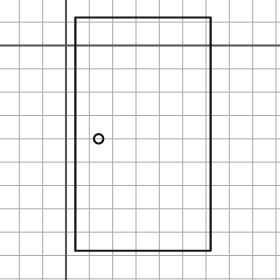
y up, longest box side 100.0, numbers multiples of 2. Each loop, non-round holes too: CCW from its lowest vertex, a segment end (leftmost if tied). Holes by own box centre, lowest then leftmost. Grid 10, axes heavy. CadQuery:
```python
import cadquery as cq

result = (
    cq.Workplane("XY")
    .moveTo(4.0, -88.0)
    .lineTo(62.0, -88.0)
    .lineTo(62.0, 12.0)
    .lineTo(4.0, 12.0)
    .close()
    .moveTo(14.0, -40.0)
    .circle(2.0)
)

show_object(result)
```